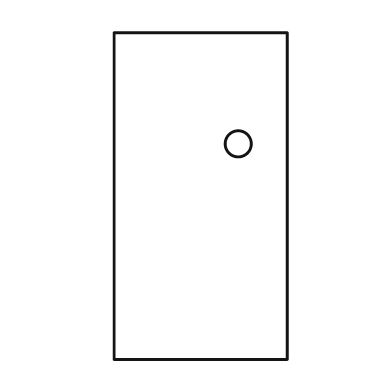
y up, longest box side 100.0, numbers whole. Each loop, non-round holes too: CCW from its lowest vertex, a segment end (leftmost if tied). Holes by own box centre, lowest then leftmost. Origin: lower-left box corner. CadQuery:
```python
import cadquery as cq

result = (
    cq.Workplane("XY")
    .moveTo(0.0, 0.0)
    .lineTo(53.0, 0.0)
    .lineTo(53.0, 100.0)
    .lineTo(0.0, 100.0)
    .close()
    .moveTo(38.0, 66.0)
    .circle(4.0)
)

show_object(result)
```